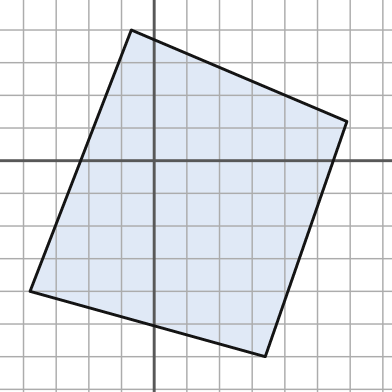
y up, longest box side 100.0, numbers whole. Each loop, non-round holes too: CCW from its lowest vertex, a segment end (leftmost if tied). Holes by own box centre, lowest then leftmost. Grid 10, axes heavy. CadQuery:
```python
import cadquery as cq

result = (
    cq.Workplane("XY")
    .moveTo(34.0, -60.0)
    .lineTo(59.0, 12.0)
    .lineTo(-7.0, 40.0)
    .lineTo(-38.0, -40.0)
    .close()
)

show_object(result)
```